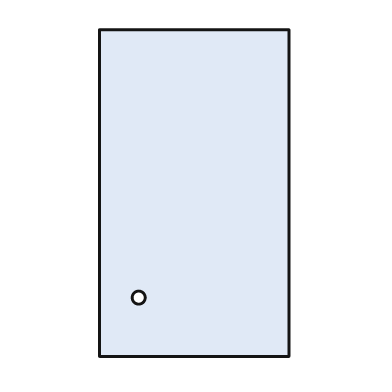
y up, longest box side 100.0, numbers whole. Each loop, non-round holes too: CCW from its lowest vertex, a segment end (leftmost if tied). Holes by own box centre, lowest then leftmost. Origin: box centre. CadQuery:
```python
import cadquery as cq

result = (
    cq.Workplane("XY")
    .moveTo(-29.0, -50.0)
    .lineTo(29.0, -50.0)
    .lineTo(29.0, 50.0)
    .lineTo(-29.0, 50.0)
    .close()
    .moveTo(-17.0, -32.0)
    .circle(2.0)
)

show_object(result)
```